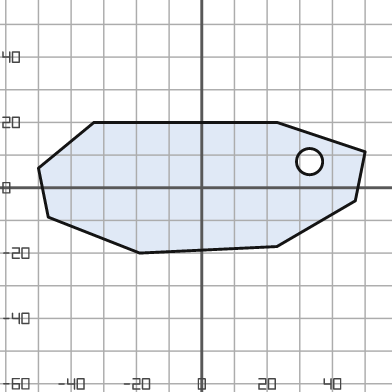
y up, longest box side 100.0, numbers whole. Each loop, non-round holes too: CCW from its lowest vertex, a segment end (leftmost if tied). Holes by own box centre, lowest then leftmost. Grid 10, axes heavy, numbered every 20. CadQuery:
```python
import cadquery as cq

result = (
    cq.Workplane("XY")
    .moveTo(-19.0, -20.0)
    .lineTo(23.0, -18.0)
    .lineTo(47.0, -4.0)
    .lineTo(50.0, 11.0)
    .lineTo(23.0, 20.0)
    .lineTo(-33.0, 20.0)
    .lineTo(-50.0, 6.0)
    .lineTo(-47.0, -9.0)
    .close()
    .moveTo(33.0, 8.0)
    .circle(4.0)
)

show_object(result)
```